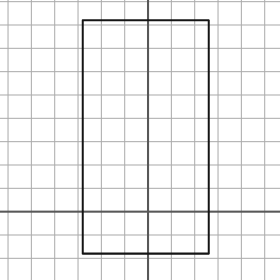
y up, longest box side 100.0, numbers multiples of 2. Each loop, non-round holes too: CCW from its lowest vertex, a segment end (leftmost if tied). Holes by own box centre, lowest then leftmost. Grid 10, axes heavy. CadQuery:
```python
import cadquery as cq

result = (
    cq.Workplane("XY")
    .moveTo(-28.0, -18.0)
    .lineTo(26.0, -18.0)
    .lineTo(26.0, 82.0)
    .lineTo(-28.0, 82.0)
    .close()
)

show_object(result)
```